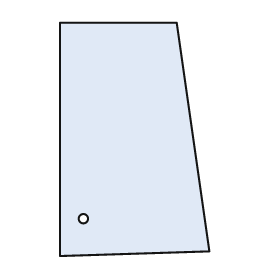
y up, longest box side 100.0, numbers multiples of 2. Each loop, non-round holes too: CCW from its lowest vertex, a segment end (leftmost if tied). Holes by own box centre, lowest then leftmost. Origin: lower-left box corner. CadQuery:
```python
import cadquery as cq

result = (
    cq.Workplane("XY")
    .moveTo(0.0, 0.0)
    .lineTo(64.0, 2.0)
    .lineTo(50.0, 100.0)
    .lineTo(0.0, 100.0)
    .close()
    .moveTo(10.0, 16.0)
    .circle(2.0)
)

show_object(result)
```